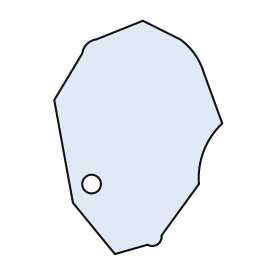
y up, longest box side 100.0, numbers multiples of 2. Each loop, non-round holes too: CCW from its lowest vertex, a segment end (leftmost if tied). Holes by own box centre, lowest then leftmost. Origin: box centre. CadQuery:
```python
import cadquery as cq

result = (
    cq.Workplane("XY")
    .moveTo(-10.0, -50.0)
    .lineTo(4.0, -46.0)
    .threePointArc((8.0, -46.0), (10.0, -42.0))
    .lineTo(26.0, -20.0)
    .threePointArc((28.0, -6.0), (36.0, 6.0))
    .lineTo(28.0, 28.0)
    .threePointArc((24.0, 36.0), (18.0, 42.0))
    .lineTo(2.0, 50.0)
    .lineTo(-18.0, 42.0)
    .threePointArc((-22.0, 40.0), (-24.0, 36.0))
    .lineTo(-36.0, 16.0)
    .lineTo(-28.0, -28.0)
    .close()
    .moveTo(-20.0, -20.0)
    .circle(4.0)
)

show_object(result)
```